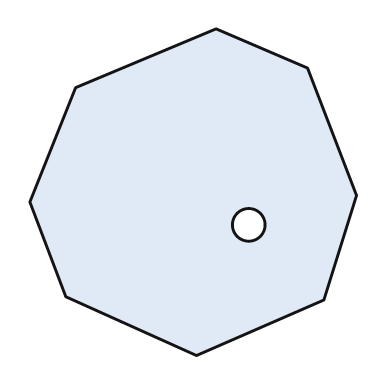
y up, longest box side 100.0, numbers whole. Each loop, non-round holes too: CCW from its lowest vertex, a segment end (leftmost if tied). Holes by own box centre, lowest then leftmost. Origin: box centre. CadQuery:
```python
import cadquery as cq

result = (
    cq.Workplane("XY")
    .moveTo(1.0, -50.0)
    .lineTo(40.0, -33.0)
    .lineTo(50.0, -1.0)
    .lineTo(35.0, 38.0)
    .lineTo(7.0, 50.0)
    .lineTo(-36.0, 32.0)
    .lineTo(-50.0, -3.0)
    .lineTo(-39.0, -32.0)
    .close()
    .moveTo(17.0, -10.0)
    .circle(5.0)
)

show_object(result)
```